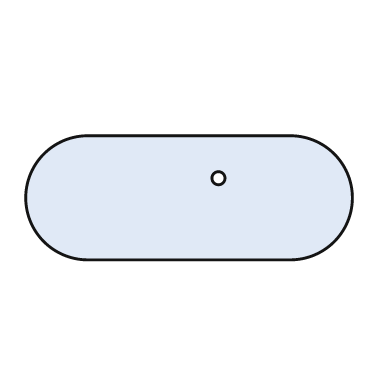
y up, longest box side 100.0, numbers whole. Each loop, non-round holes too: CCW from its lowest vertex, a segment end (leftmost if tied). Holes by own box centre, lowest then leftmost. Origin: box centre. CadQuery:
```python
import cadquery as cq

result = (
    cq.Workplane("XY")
    .moveTo(-31.0, -19.0)
    .lineTo(31.0, -19.0)
    .threePointArc((50.0, 0.0), (31.0, 19.0))
    .lineTo(-31.0, 19.0)
    .threePointArc((-50.0, 0.0), (-31.0, -19.0))
    .close()
    .moveTo(9.0, 6.0)
    .circle(2.0)
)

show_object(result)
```